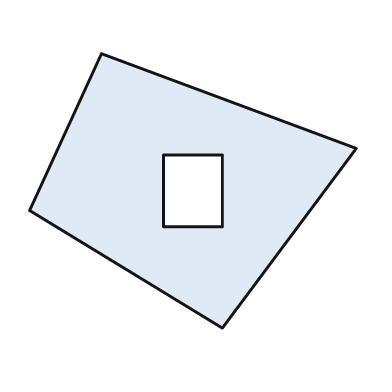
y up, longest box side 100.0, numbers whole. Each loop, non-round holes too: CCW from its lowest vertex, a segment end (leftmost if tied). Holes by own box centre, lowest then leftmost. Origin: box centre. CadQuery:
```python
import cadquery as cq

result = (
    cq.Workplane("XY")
    .moveTo(9.0, -42.0)
    .lineTo(50.0, 13.0)
    .lineTo(-28.0, 42.0)
    .lineTo(-50.0, -6.0)
    .close()
    .moveTo(-9.0, -11.0)
    .lineTo(9.0, -11.0)
    .lineTo(9.0, 11.0)
    .lineTo(-9.0, 11.0)
    .close()
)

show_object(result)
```